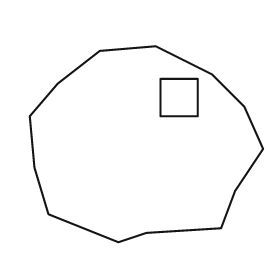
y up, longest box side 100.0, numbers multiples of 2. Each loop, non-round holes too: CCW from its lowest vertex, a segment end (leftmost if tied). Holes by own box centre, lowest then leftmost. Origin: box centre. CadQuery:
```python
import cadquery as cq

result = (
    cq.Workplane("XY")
    .moveTo(-12.0, -42.0)
    .lineTo(0.0, -38.0)
    .lineTo(32.0, -36.0)
    .lineTo(38.0, -20.0)
    .lineTo(50.0, -2.0)
    .lineTo(42.0, 16.0)
    .lineTo(28.0, 30.0)
    .lineTo(4.0, 42.0)
    .lineTo(-20.0, 40.0)
    .lineTo(-38.0, 26.0)
    .lineTo(-50.0, 12.0)
    .lineTo(-48.0, -10.0)
    .lineTo(-42.0, -30.0)
    .close()
    .moveTo(6.0, 12.0)
    .lineTo(22.0, 12.0)
    .lineTo(22.0, 28.0)
    .lineTo(6.0, 28.0)
    .close()
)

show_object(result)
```